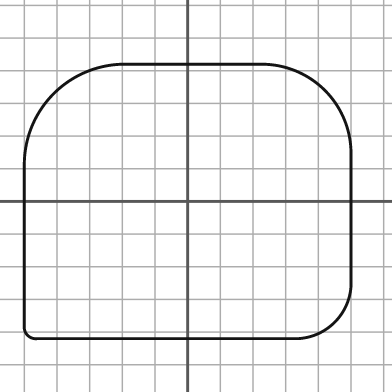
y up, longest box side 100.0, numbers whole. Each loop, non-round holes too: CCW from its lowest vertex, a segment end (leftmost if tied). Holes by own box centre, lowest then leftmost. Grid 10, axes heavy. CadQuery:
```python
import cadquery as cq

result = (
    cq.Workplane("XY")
    .moveTo(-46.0, -42.0)
    .lineTo(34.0, -42.0)
    .threePointArc((45.0, -37.0), (50.0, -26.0))
    .lineTo(50.0, 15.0)
    .threePointArc((42.0, 34.0), (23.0, 42.0))
    .lineTo(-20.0, 42.0)
    .threePointArc((-41.0, 33.0), (-50.0, 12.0))
    .lineTo(-50.0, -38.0)
    .threePointArc((-49.0, -41.0), (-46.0, -42.0))
    .close()
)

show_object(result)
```